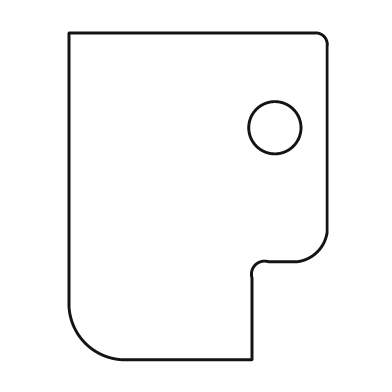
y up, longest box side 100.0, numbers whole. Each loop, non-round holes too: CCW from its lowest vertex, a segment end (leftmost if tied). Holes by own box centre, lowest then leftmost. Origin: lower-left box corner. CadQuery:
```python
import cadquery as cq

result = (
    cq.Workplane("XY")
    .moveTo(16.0, 0.0)
    .lineTo(56.0, 0.0)
    .lineTo(56.0, 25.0)
    .threePointArc((57.0, 29.0), (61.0, 30.0))
    .lineTo(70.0, 30.0)
    .threePointArc((76.0, 33.0), (79.0, 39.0))
    .lineTo(79.0, 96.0)
    .threePointArc((78.0, 99.0), (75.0, 100.0))
    .lineTo(0.0, 100.0)
    .lineTo(0.0, 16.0)
    .threePointArc((5.0, 5.0), (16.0, 0.0))
    .close()
    .moveTo(63.0, 71.0)
    .circle(8.0)
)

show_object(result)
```